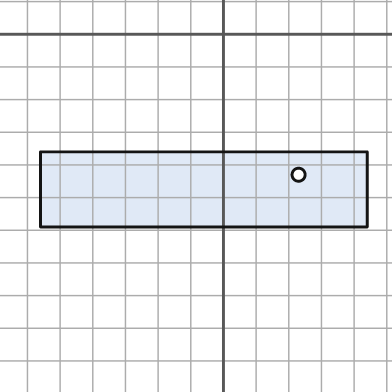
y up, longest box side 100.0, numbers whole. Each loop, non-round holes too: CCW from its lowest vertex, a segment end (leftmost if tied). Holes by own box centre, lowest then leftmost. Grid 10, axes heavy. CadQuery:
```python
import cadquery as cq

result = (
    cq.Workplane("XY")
    .moveTo(-56.0, -59.0)
    .lineTo(44.0, -59.0)
    .lineTo(44.0, -36.0)
    .lineTo(-56.0, -36.0)
    .close()
    .moveTo(23.0, -43.0)
    .circle(2.0)
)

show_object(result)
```